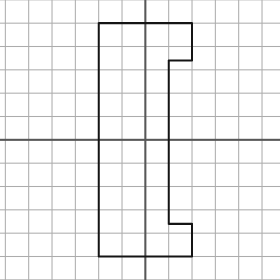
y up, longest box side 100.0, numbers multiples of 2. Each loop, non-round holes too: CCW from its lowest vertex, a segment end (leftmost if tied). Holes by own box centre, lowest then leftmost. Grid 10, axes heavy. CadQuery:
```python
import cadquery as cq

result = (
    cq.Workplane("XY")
    .moveTo(-20.0, -50.0)
    .lineTo(20.0, -50.0)
    .lineTo(20.0, -36.0)
    .lineTo(10.0, -36.0)
    .lineTo(10.0, 34.0)
    .lineTo(20.0, 34.0)
    .lineTo(20.0, 50.0)
    .lineTo(-20.0, 50.0)
    .close()
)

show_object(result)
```